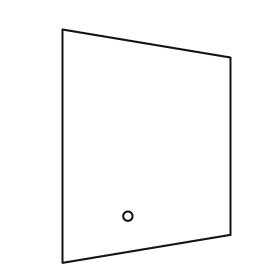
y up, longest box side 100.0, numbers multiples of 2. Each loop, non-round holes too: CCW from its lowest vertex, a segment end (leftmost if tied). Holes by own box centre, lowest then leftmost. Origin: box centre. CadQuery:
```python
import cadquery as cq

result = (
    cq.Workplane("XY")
    .moveTo(-36.0, -50.0)
    .lineTo(36.0, -38.0)
    .lineTo(36.0, 38.0)
    .lineTo(-36.0, 50.0)
    .close()
    .moveTo(-8.0, -30.0)
    .circle(2.0)
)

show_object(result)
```